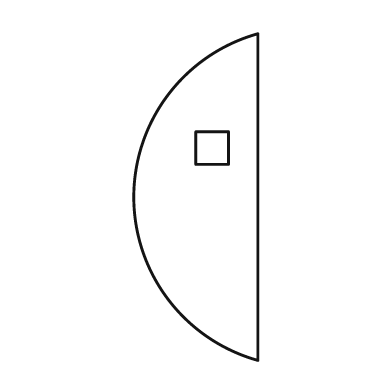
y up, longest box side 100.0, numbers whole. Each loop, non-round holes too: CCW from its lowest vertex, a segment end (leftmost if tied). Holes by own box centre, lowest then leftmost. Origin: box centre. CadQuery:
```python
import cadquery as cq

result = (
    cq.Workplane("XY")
    .moveTo(19.0, -50.0)
    .lineTo(19.0, 50.0)
    .threePointArc((-19.0, 0.0), (19.0, -50.0))
    .close()
    .moveTo(0.0, 10.0)
    .lineTo(10.0, 10.0)
    .lineTo(10.0, 20.0)
    .lineTo(0.0, 20.0)
    .close()
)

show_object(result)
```